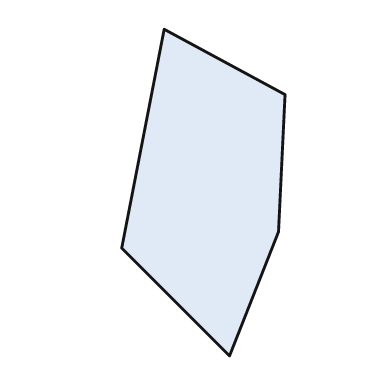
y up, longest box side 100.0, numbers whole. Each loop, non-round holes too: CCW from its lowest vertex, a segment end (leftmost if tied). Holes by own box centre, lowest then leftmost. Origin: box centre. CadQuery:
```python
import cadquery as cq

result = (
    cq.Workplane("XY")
    .moveTo(8.0, -50.0)
    .lineTo(23.0, -12.0)
    .lineTo(25.0, 30.0)
    .lineTo(-12.0, 50.0)
    .lineTo(-25.0, -17.0)
    .close()
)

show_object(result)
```